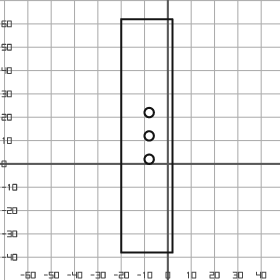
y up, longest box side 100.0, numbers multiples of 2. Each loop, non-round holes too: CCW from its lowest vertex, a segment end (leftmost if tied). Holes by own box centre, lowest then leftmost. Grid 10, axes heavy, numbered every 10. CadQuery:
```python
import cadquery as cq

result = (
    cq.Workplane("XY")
    .moveTo(-20.0, -38.0)
    .lineTo(2.0, -38.0)
    .lineTo(2.0, 62.0)
    .lineTo(-20.0, 62.0)
    .close()
    .moveTo(-8.0, 2.0)
    .circle(2.0)
    .moveTo(-8.0, 12.0)
    .circle(2.0)
    .moveTo(-8.0, 22.0)
    .circle(2.0)
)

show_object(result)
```